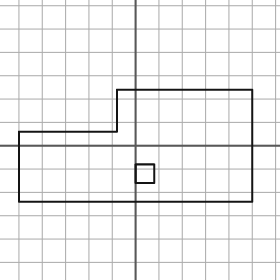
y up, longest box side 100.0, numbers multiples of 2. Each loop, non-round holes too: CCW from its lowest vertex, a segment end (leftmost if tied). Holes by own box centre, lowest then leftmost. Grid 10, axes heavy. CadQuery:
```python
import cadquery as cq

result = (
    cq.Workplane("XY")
    .moveTo(-50.0, -24.0)
    .lineTo(50.0, -24.0)
    .lineTo(50.0, 24.0)
    .lineTo(-8.0, 24.0)
    .lineTo(-8.0, 6.0)
    .lineTo(-50.0, 6.0)
    .close()
    .moveTo(0.0, -16.0)
    .lineTo(8.0, -16.0)
    .lineTo(8.0, -8.0)
    .lineTo(0.0, -8.0)
    .close()
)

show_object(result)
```